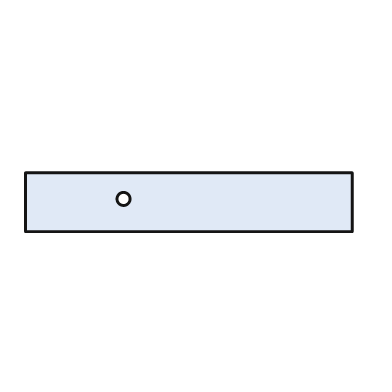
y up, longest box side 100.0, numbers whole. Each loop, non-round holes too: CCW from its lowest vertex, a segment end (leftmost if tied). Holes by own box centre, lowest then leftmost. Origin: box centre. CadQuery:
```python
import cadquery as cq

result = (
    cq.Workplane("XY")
    .moveTo(-50.0, -9.0)
    .lineTo(50.0, -9.0)
    .lineTo(50.0, 9.0)
    .lineTo(-50.0, 9.0)
    .close()
    .moveTo(-20.0, 1.0)
    .circle(2.0)
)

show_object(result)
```